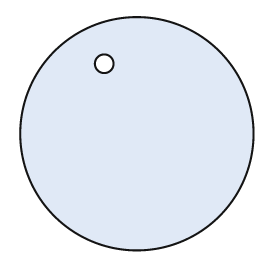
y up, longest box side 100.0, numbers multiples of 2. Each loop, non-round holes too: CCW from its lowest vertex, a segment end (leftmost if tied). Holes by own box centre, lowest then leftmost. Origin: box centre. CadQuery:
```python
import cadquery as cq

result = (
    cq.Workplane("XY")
    .moveTo(0.0, 0.0)
    .circle(50.0)
    .moveTo(-14.0, 30.0)
    .circle(4.0)
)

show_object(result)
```